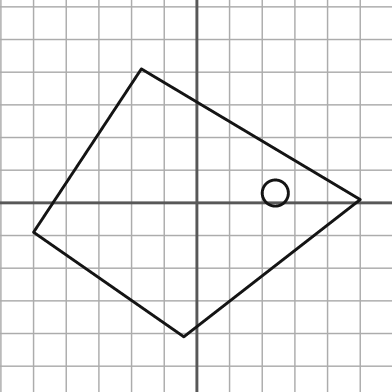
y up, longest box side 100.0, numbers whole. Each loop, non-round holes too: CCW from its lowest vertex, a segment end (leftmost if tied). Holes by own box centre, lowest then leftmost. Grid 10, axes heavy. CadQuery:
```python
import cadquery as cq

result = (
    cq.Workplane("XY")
    .moveTo(-4.0, -41.0)
    .lineTo(50.0, 1.0)
    .lineTo(-17.0, 41.0)
    .lineTo(-50.0, -9.0)
    .close()
    .moveTo(24.0, 3.0)
    .circle(4.0)
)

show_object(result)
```